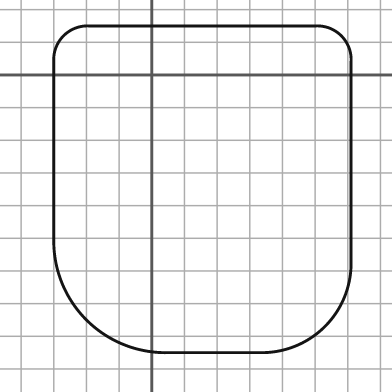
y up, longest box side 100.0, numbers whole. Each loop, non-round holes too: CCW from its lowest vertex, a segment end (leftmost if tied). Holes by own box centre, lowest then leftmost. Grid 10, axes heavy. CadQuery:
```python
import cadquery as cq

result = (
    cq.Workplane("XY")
    .moveTo(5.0, -85.0)
    .lineTo(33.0, -85.0)
    .threePointArc((53.0, -77.0), (61.0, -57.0))
    .lineTo(61.0, 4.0)
    .threePointArc((58.0, 12.0), (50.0, 15.0))
    .lineTo(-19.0, 15.0)
    .threePointArc((-27.0, 12.0), (-30.0, 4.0))
    .lineTo(-30.0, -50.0)
    .threePointArc((-20.0, -75.0), (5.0, -85.0))
    .close()
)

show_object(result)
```